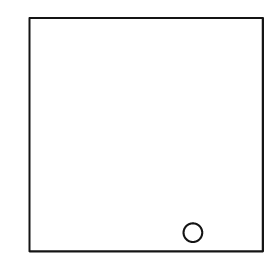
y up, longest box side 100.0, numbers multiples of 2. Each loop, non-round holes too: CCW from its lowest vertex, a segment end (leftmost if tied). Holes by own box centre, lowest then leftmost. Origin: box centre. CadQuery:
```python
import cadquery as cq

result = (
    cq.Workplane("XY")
    .moveTo(-50.0, -50.0)
    .lineTo(50.0, -50.0)
    .lineTo(50.0, 50.0)
    .lineTo(-50.0, 50.0)
    .close()
    .moveTo(20.0, -42.0)
    .circle(4.0)
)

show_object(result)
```